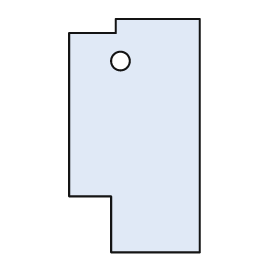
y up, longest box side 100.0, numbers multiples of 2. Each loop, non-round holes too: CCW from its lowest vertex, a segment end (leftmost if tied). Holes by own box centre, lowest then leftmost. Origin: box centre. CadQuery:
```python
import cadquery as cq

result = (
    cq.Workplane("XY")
    .moveTo(-10.0, -50.0)
    .lineTo(28.0, -50.0)
    .lineTo(28.0, 50.0)
    .lineTo(-8.0, 50.0)
    .lineTo(-8.0, 44.0)
    .lineTo(-28.0, 44.0)
    .lineTo(-28.0, -26.0)
    .lineTo(-10.0, -26.0)
    .close()
    .moveTo(-6.0, 32.0)
    .circle(4.0)
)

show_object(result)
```